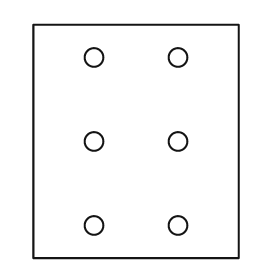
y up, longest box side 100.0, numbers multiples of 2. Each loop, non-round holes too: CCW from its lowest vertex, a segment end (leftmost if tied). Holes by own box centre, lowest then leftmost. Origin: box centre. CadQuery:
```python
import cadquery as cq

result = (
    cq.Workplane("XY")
    .moveTo(-44.0, -50.0)
    .lineTo(44.0, -50.0)
    .lineTo(44.0, 50.0)
    .lineTo(-44.0, 50.0)
    .close()
    .moveTo(-18.0, -36.0)
    .circle(4.0)
    .moveTo(18.0, -36.0)
    .circle(4.0)
    .moveTo(-18.0, 0.0)
    .circle(4.0)
    .moveTo(18.0, 0.0)
    .circle(4.0)
    .moveTo(-18.0, 36.0)
    .circle(4.0)
    .moveTo(18.0, 36.0)
    .circle(4.0)
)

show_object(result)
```